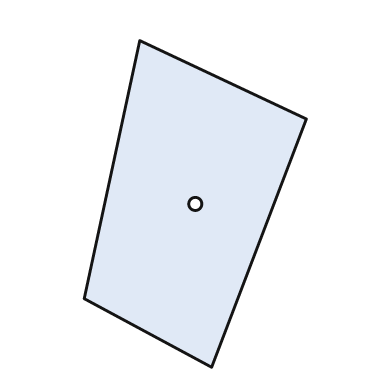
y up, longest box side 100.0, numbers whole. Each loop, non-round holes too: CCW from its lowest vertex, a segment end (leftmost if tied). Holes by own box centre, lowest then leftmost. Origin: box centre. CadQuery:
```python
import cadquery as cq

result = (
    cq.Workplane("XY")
    .moveTo(5.0, -50.0)
    .lineTo(34.0, 26.0)
    .lineTo(-17.0, 50.0)
    .lineTo(-34.0, -29.0)
    .close()
    .moveTo(0.0, 0.0)
    .circle(2.0)
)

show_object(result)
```